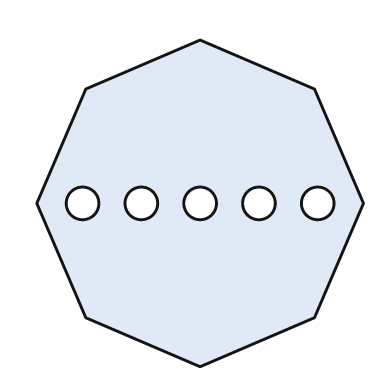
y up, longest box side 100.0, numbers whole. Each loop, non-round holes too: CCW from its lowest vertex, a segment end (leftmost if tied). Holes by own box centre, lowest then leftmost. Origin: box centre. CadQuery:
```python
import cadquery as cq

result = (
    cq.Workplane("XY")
    .moveTo(0.0, -50.0)
    .lineTo(35.0, -35.0)
    .lineTo(50.0, 0.0)
    .lineTo(35.0, 35.0)
    .lineTo(0.0, 50.0)
    .lineTo(-35.0, 35.0)
    .lineTo(-50.0, 0.0)
    .lineTo(-35.0, -35.0)
    .close()
    .moveTo(-36.0, 0.0)
    .circle(5.0)
    .moveTo(-18.0, 0.0)
    .circle(5.0)
    .moveTo(0.0, 0.0)
    .circle(5.0)
    .moveTo(18.0, 0.0)
    .circle(5.0)
    .moveTo(36.0, 0.0)
    .circle(5.0)
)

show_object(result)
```